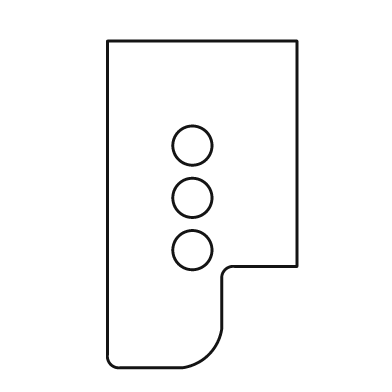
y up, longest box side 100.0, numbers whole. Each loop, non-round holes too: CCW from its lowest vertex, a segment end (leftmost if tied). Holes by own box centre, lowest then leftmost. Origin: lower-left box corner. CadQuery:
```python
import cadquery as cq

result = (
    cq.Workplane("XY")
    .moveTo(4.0, 0.0)
    .lineTo(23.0, 0.0)
    .threePointArc((31.0, 4.0), (35.0, 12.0))
    .lineTo(35.0, 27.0)
    .threePointArc((36.0, 30.0), (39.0, 31.0))
    .lineTo(58.0, 31.0)
    .lineTo(58.0, 100.0)
    .lineTo(0.0, 100.0)
    .lineTo(0.0, 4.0)
    .threePointArc((1.0, 1.0), (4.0, 0.0))
    .close()
    .moveTo(26.0, 36.0)
    .circle(6.0)
    .moveTo(26.0, 52.0)
    .circle(6.0)
    .moveTo(26.0, 68.0)
    .circle(6.0)
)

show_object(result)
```